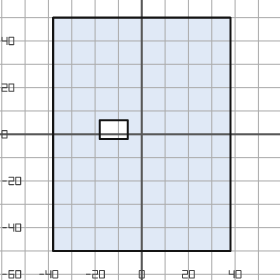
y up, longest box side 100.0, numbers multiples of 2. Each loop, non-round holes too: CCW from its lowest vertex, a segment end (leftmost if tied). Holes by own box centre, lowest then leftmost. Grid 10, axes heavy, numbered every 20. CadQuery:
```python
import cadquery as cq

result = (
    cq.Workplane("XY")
    .moveTo(-38.0, -50.0)
    .lineTo(38.0, -50.0)
    .lineTo(38.0, 50.0)
    .lineTo(-38.0, 50.0)
    .close()
    .moveTo(-18.0, -2.0)
    .lineTo(-6.0, -2.0)
    .lineTo(-6.0, 6.0)
    .lineTo(-18.0, 6.0)
    .close()
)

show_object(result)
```